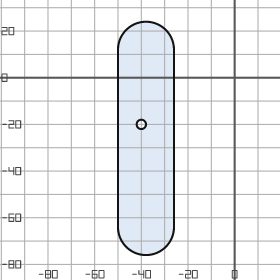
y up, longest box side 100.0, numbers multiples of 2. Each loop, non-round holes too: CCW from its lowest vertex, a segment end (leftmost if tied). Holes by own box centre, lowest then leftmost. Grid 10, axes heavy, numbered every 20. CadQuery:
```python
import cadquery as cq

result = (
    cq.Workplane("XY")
    .moveTo(-50.0, -64.0)
    .threePointArc((-38.0, -76.0), (-26.0, -64.0))
    .lineTo(-26.0, 12.0)
    .threePointArc((-38.0, 24.0), (-50.0, 12.0))
    .close()
    .moveTo(-40.0, -20.0)
    .circle(2.0)
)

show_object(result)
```